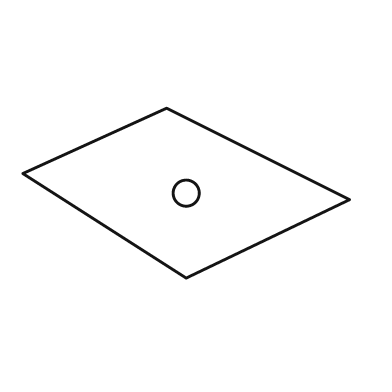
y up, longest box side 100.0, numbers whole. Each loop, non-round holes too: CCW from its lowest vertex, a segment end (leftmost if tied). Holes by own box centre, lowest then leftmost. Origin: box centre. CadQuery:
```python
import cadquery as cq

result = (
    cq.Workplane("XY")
    .moveTo(0.0, -26.0)
    .lineTo(50.0, -2.0)
    .lineTo(-6.0, 26.0)
    .lineTo(-50.0, 6.0)
    .close()
    .moveTo(0.0, 0.0)
    .circle(4.0)
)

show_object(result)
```